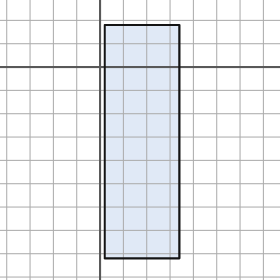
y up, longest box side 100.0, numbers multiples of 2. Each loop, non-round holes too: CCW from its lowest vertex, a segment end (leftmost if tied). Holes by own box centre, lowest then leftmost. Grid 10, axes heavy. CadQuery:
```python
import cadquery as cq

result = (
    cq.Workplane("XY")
    .moveTo(2.0, -82.0)
    .lineTo(34.0, -82.0)
    .lineTo(34.0, 18.0)
    .lineTo(2.0, 18.0)
    .close()
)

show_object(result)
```